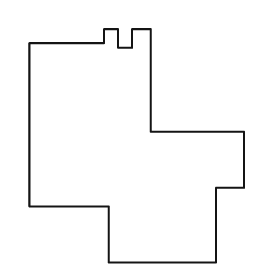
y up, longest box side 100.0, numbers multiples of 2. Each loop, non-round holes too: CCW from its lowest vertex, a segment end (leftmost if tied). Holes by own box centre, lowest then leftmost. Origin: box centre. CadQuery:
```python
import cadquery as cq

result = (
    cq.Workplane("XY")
    .moveTo(-12.0, -50.0)
    .lineTo(34.0, -50.0)
    .lineTo(34.0, -18.0)
    .lineTo(46.0, -18.0)
    .lineTo(46.0, 6.0)
    .lineTo(6.0, 6.0)
    .lineTo(6.0, 50.0)
    .lineTo(-2.0, 50.0)
    .lineTo(-2.0, 42.0)
    .lineTo(-8.0, 42.0)
    .lineTo(-8.0, 50.0)
    .lineTo(-14.0, 50.0)
    .lineTo(-14.0, 44.0)
    .lineTo(-46.0, 44.0)
    .lineTo(-46.0, -26.0)
    .lineTo(-12.0, -26.0)
    .close()
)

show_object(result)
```